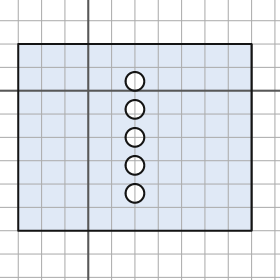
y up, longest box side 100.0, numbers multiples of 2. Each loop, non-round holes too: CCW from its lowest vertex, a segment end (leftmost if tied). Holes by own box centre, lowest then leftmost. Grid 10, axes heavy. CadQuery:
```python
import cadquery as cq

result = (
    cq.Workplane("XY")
    .moveTo(-30.0, -60.0)
    .lineTo(70.0, -60.0)
    .lineTo(70.0, 20.0)
    .lineTo(-30.0, 20.0)
    .close()
    .moveTo(20.0, -44.0)
    .circle(4.0)
    .moveTo(20.0, -32.0)
    .circle(4.0)
    .moveTo(20.0, -20.0)
    .circle(4.0)
    .moveTo(20.0, -8.0)
    .circle(4.0)
    .moveTo(20.0, 4.0)
    .circle(4.0)
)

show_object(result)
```